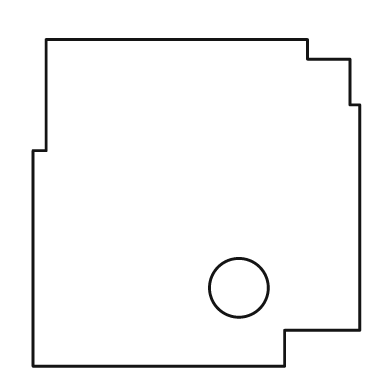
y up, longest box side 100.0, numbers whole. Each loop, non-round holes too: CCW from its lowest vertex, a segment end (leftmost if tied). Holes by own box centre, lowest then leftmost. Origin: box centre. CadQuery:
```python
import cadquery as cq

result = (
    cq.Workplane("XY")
    .moveTo(-50.0, -50.0)
    .lineTo(27.0, -50.0)
    .lineTo(27.0, -39.0)
    .lineTo(50.0, -39.0)
    .lineTo(50.0, 30.0)
    .lineTo(47.0, 30.0)
    .lineTo(47.0, 44.0)
    .lineTo(34.0, 44.0)
    .lineTo(34.0, 50.0)
    .lineTo(-46.0, 50.0)
    .lineTo(-46.0, 16.0)
    .lineTo(-50.0, 16.0)
    .close()
    .moveTo(13.0, -26.0)
    .circle(9.0)
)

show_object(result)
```